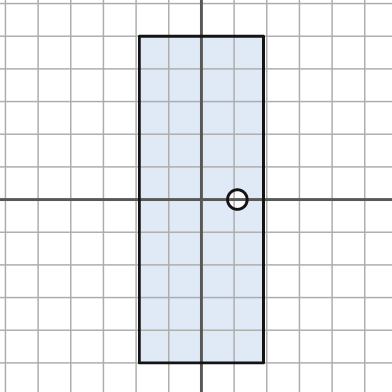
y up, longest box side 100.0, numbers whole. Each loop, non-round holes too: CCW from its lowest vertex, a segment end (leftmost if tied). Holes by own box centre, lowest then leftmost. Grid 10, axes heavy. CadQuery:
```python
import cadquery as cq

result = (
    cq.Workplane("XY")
    .moveTo(-19.0, -50.0)
    .lineTo(19.0, -50.0)
    .lineTo(19.0, 50.0)
    .lineTo(-19.0, 50.0)
    .close()
    .moveTo(11.0, 0.0)
    .circle(3.0)
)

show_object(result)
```